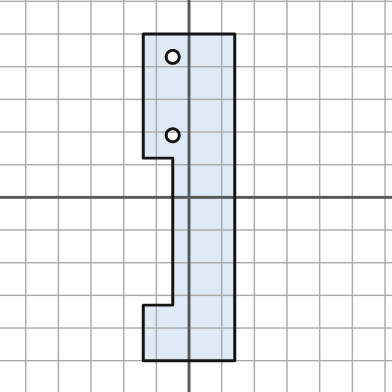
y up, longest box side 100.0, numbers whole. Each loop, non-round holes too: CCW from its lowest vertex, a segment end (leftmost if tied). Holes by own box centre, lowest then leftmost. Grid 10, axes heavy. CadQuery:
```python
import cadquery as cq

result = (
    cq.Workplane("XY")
    .moveTo(-14.0, -50.0)
    .lineTo(14.0, -50.0)
    .lineTo(14.0, 50.0)
    .lineTo(-14.0, 50.0)
    .lineTo(-14.0, 12.0)
    .lineTo(-5.0, 12.0)
    .lineTo(-5.0, -33.0)
    .lineTo(-14.0, -33.0)
    .close()
    .moveTo(-5.0, 19.0)
    .circle(2.0)
    .moveTo(-5.0, 43.0)
    .circle(2.0)
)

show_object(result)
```